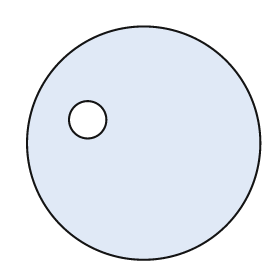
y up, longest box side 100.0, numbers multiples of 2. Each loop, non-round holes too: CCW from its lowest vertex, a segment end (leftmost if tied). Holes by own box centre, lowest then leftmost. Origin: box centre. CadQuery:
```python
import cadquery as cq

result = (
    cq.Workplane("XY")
    .moveTo(0.0, 0.0)
    .circle(50.0)
    .moveTo(-24.0, 10.0)
    .circle(8.0)
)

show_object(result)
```